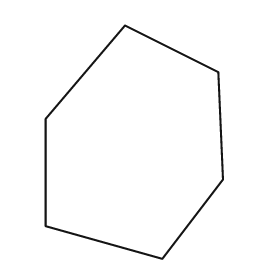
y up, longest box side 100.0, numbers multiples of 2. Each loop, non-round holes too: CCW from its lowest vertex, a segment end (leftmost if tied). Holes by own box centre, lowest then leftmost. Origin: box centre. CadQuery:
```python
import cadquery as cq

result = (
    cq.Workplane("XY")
    .moveTo(12.0, -50.0)
    .lineTo(38.0, -16.0)
    .lineTo(36.0, 30.0)
    .lineTo(-4.0, 50.0)
    .lineTo(-38.0, 10.0)
    .lineTo(-38.0, -36.0)
    .close()
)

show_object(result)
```